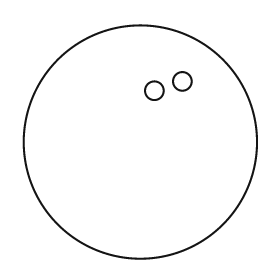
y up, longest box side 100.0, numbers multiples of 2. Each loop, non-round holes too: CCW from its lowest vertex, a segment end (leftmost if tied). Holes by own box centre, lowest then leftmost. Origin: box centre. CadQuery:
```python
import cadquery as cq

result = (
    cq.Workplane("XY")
    .moveTo(0.0, 0.0)
    .circle(50.0)
    .moveTo(6.0, 22.0)
    .circle(4.0)
    .moveTo(18.0, 26.0)
    .circle(4.0)
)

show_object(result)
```